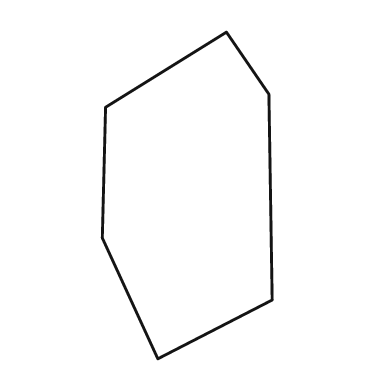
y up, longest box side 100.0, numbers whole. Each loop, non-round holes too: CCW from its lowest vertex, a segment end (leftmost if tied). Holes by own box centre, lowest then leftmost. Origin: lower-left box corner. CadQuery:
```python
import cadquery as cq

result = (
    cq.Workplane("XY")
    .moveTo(17.0, 0.0)
    .lineTo(52.0, 18.0)
    .lineTo(51.0, 81.0)
    .lineTo(38.0, 100.0)
    .lineTo(1.0, 77.0)
    .lineTo(0.0, 37.0)
    .close()
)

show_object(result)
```